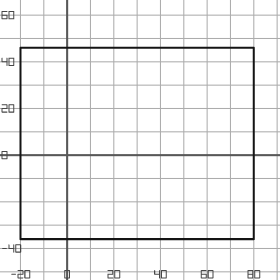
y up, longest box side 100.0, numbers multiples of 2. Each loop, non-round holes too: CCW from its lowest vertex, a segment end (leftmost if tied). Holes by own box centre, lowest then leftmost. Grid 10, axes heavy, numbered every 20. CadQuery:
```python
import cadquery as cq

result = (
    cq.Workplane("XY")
    .moveTo(-20.0, -36.0)
    .lineTo(80.0, -36.0)
    .lineTo(80.0, 46.0)
    .lineTo(-20.0, 46.0)
    .close()
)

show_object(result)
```